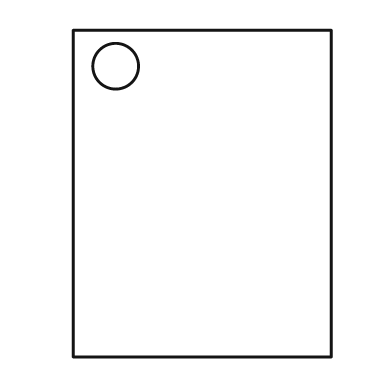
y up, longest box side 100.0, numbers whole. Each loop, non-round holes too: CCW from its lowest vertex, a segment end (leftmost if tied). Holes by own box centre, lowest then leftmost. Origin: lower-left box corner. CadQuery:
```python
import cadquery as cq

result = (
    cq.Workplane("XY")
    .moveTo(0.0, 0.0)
    .lineTo(79.0, 0.0)
    .lineTo(79.0, 100.0)
    .lineTo(0.0, 100.0)
    .close()
    .moveTo(13.0, 89.0)
    .circle(7.0)
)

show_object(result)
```